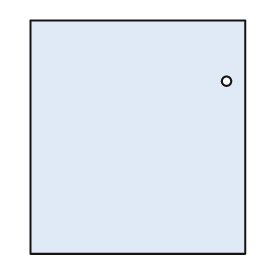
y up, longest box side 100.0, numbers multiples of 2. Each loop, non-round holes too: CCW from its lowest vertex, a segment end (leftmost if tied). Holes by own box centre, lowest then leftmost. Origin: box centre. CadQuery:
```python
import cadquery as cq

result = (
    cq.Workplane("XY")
    .moveTo(-46.0, -50.0)
    .lineTo(46.0, -50.0)
    .lineTo(46.0, 50.0)
    .lineTo(-46.0, 50.0)
    .close()
    .moveTo(38.0, 24.0)
    .circle(2.0)
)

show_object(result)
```